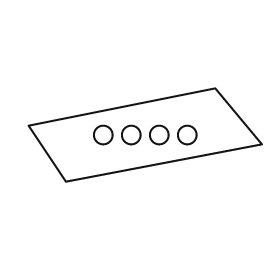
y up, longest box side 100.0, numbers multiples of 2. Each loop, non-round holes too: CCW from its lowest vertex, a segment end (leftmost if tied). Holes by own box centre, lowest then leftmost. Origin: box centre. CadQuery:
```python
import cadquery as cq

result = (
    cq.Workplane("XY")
    .moveTo(-34.0, -20.0)
    .lineTo(50.0, -4.0)
    .lineTo(30.0, 20.0)
    .lineTo(-50.0, 4.0)
    .close()
    .moveTo(-18.0, 0.0)
    .circle(4.0)
    .moveTo(-6.0, 0.0)
    .circle(4.0)
    .moveTo(6.0, 0.0)
    .circle(4.0)
    .moveTo(18.0, 0.0)
    .circle(4.0)
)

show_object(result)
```